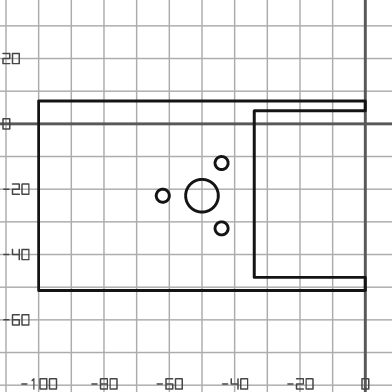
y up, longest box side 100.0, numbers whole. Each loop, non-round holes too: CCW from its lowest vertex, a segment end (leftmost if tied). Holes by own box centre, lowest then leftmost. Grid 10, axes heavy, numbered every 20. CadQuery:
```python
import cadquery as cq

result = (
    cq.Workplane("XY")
    .moveTo(-100.0, -51.0)
    .lineTo(0.0, -51.0)
    .lineTo(0.0, -47.0)
    .lineTo(-34.0, -47.0)
    .lineTo(-34.0, 4.0)
    .lineTo(0.0, 4.0)
    .lineTo(0.0, 7.0)
    .lineTo(-100.0, 7.0)
    .close()
    .moveTo(-44.0, -32.0)
    .circle(2.0)
    .moveTo(-62.0, -22.0)
    .circle(2.0)
    .moveTo(-50.0, -22.0)
    .circle(5.0)
    .moveTo(-44.0, -12.0)
    .circle(2.0)
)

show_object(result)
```